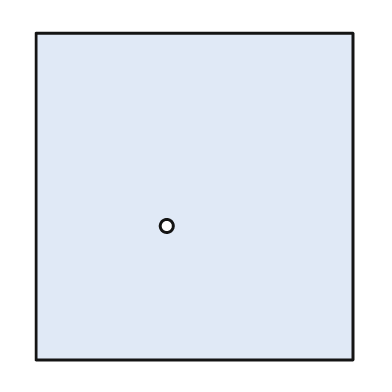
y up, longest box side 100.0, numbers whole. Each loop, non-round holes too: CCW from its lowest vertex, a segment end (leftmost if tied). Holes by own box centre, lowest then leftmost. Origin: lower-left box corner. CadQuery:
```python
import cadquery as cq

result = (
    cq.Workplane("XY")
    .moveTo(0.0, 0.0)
    .lineTo(97.0, 0.0)
    .lineTo(97.0, 100.0)
    .lineTo(0.0, 100.0)
    .close()
    .moveTo(40.0, 41.0)
    .circle(2.0)
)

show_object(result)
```